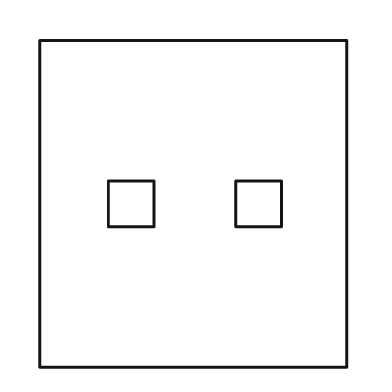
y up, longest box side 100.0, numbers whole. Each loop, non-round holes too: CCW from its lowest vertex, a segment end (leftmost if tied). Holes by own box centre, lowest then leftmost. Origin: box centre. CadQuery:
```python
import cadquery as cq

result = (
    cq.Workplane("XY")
    .moveTo(-47.0, -50.0)
    .lineTo(47.0, -50.0)
    .lineTo(47.0, 50.0)
    .lineTo(-47.0, 50.0)
    .close()
    .moveTo(-26.0, -7.0)
    .lineTo(-12.0, -7.0)
    .lineTo(-12.0, 7.0)
    .lineTo(-26.0, 7.0)
    .close()
    .moveTo(13.0, -7.0)
    .lineTo(27.0, -7.0)
    .lineTo(27.0, 7.0)
    .lineTo(13.0, 7.0)
    .close()
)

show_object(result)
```